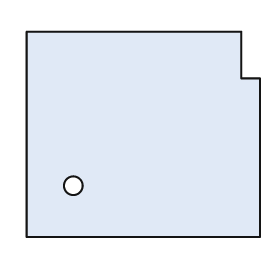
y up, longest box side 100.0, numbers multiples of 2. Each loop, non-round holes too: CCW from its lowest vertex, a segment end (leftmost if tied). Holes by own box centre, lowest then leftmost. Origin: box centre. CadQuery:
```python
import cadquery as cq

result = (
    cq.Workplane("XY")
    .moveTo(-50.0, -44.0)
    .lineTo(50.0, -44.0)
    .lineTo(50.0, 24.0)
    .lineTo(42.0, 24.0)
    .lineTo(42.0, 44.0)
    .lineTo(-50.0, 44.0)
    .close()
    .moveTo(-30.0, -22.0)
    .circle(4.0)
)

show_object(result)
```